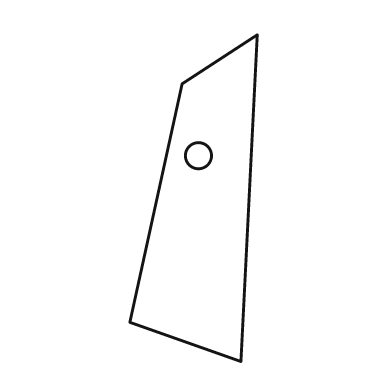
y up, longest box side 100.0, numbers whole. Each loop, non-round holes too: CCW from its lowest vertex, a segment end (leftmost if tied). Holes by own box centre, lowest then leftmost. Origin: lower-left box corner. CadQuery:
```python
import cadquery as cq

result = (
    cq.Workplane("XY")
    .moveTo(34.0, 0.0)
    .lineTo(39.0, 100.0)
    .lineTo(16.0, 85.0)
    .lineTo(0.0, 12.0)
    .close()
    .moveTo(21.0, 63.0)
    .circle(4.0)
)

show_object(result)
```